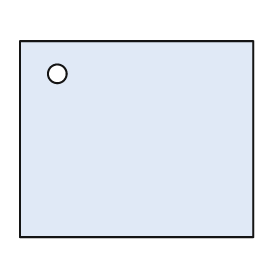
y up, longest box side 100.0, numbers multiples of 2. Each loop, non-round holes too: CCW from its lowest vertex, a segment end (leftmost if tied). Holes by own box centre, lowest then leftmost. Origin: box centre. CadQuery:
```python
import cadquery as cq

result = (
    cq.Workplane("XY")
    .moveTo(-50.0, -42.0)
    .lineTo(50.0, -42.0)
    .lineTo(50.0, 42.0)
    .lineTo(-50.0, 42.0)
    .close()
    .moveTo(-34.0, 28.0)
    .circle(4.0)
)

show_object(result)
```